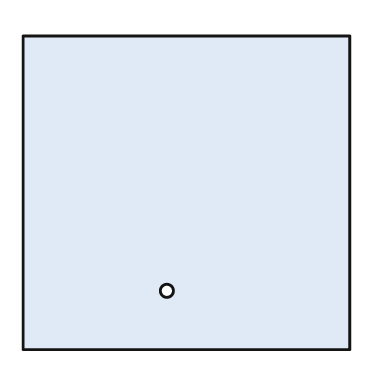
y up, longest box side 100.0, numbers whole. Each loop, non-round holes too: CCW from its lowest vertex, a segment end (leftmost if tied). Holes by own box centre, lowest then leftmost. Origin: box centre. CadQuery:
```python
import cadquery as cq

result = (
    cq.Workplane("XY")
    .moveTo(-50.0, -48.0)
    .lineTo(50.0, -48.0)
    .lineTo(50.0, 48.0)
    .lineTo(-50.0, 48.0)
    .close()
    .moveTo(-6.0, -30.0)
    .circle(2.0)
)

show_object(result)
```